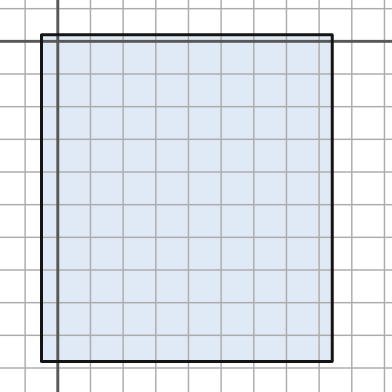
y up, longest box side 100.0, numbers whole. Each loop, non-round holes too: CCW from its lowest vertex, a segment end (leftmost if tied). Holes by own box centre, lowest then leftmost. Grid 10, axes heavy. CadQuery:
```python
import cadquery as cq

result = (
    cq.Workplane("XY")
    .moveTo(-5.0, -98.0)
    .lineTo(84.0, -98.0)
    .lineTo(84.0, 2.0)
    .lineTo(-5.0, 2.0)
    .close()
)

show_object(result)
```